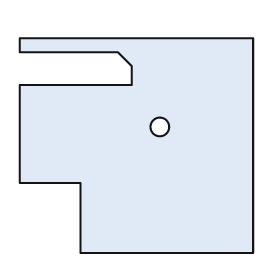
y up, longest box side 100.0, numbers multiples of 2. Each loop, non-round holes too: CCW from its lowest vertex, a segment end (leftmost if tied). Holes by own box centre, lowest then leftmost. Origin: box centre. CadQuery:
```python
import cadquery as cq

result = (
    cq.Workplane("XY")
    .moveTo(-24.0, -46.0)
    .lineTo(50.0, -46.0)
    .lineTo(50.0, 46.0)
    .lineTo(-50.0, 46.0)
    .lineTo(-50.0, 40.0)
    .lineTo(-8.0, 40.0)
    .lineTo(-2.0, 34.0)
    .lineTo(-2.0, 26.0)
    .lineTo(-50.0, 26.0)
    .lineTo(-50.0, -16.0)
    .lineTo(-24.0, -16.0)
    .close()
    .moveTo(10.0, 8.0)
    .circle(4.0)
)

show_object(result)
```